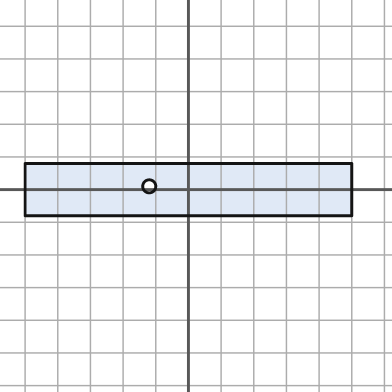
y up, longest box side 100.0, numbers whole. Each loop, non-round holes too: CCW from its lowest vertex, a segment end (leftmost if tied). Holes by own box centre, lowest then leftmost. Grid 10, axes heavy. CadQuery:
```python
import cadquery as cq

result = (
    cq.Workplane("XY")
    .moveTo(-50.0, -8.0)
    .lineTo(50.0, -8.0)
    .lineTo(50.0, 8.0)
    .lineTo(-50.0, 8.0)
    .close()
    .moveTo(-12.0, 1.0)
    .circle(2.0)
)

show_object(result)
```